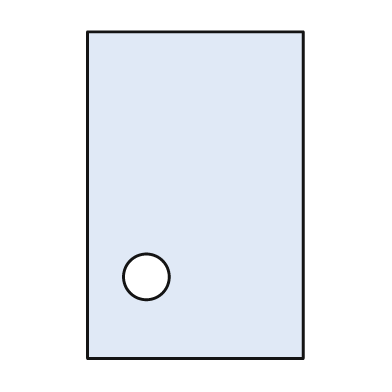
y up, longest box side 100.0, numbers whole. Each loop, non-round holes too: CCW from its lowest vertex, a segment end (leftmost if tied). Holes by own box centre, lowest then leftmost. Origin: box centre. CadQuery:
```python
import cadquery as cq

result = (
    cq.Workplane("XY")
    .moveTo(-33.0, -50.0)
    .lineTo(33.0, -50.0)
    .lineTo(33.0, 50.0)
    .lineTo(-33.0, 50.0)
    .close()
    .moveTo(-15.0, -25.0)
    .circle(7.0)
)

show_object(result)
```